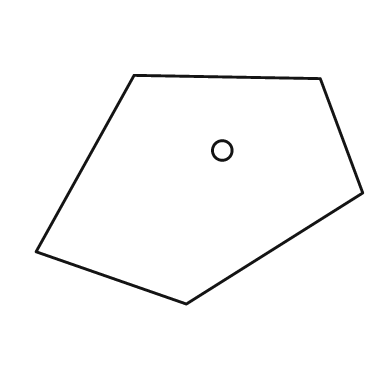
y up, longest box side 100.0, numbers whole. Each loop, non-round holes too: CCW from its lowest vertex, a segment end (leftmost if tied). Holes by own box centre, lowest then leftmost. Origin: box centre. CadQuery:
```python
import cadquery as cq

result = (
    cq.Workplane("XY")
    .moveTo(-4.0, -35.0)
    .lineTo(50.0, -1.0)
    .lineTo(37.0, 34.0)
    .lineTo(-20.0, 35.0)
    .lineTo(-50.0, -19.0)
    .close()
    .moveTo(7.0, 12.0)
    .circle(3.0)
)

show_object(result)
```